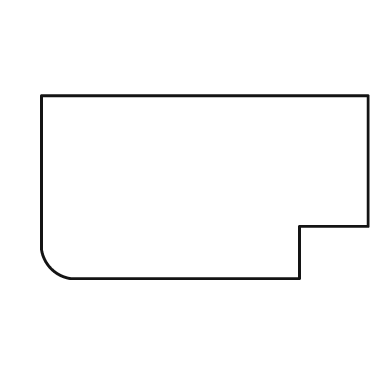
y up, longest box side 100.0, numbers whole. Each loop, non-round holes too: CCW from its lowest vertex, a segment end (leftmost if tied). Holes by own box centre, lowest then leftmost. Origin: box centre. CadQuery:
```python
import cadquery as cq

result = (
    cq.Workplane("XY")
    .moveTo(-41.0, -28.0)
    .lineTo(29.0, -28.0)
    .lineTo(29.0, -12.0)
    .lineTo(50.0, -12.0)
    .lineTo(50.0, 28.0)
    .lineTo(-50.0, 28.0)
    .lineTo(-50.0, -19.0)
    .threePointArc((-47.0, -25.0), (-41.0, -28.0))
    .close()
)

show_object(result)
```